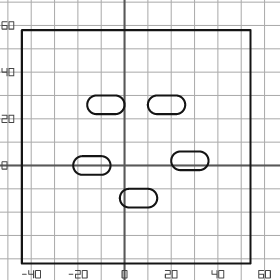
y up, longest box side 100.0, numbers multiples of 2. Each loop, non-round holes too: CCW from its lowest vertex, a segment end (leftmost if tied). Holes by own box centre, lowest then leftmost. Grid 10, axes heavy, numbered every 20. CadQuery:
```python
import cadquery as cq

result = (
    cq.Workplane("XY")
    .moveTo(-44.0, -42.0)
    .lineTo(54.0, -42.0)
    .lineTo(54.0, 58.0)
    .lineTo(-44.0, 58.0)
    .close()
    .moveTo(2.0, -18.0)
    .lineTo(10.0, -18.0)
    .threePointArc((14.0, -14.0), (10.0, -10.0))
    .lineTo(2.0, -10.0)
    .threePointArc((-2.0, -14.0), (2.0, -18.0))
    .close()
    .moveTo(-18.0, -4.0)
    .lineTo(-10.0, -4.0)
    .threePointArc((-6.0, 0.0), (-10.0, 4.0))
    .lineTo(-18.0, 4.0)
    .threePointArc((-22.0, 0.0), (-18.0, -4.0))
    .close()
    .moveTo(24.0, -2.0)
    .lineTo(32.0, -2.0)
    .threePointArc((36.0, 2.0), (32.0, 6.0))
    .lineTo(24.0, 6.0)
    .threePointArc((20.0, 2.0), (24.0, -2.0))
    .close()
    .moveTo(-12.0, 22.0)
    .lineTo(-4.0, 22.0)
    .threePointArc((0.0, 26.0), (-4.0, 30.0))
    .lineTo(-12.0, 30.0)
    .threePointArc((-16.0, 26.0), (-12.0, 22.0))
    .close()
    .moveTo(14.0, 22.0)
    .lineTo(22.0, 22.0)
    .threePointArc((26.0, 26.0), (22.0, 30.0))
    .lineTo(14.0, 30.0)
    .threePointArc((10.0, 26.0), (14.0, 22.0))
    .close()
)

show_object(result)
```